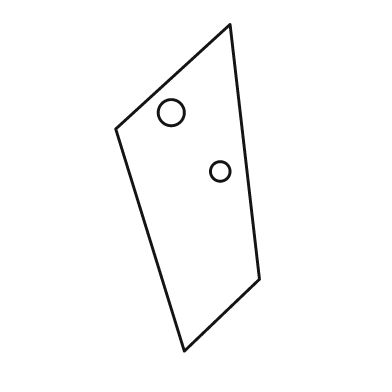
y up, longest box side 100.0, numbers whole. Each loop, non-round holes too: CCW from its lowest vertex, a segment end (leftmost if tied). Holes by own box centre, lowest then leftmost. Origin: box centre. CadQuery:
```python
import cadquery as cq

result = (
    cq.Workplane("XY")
    .moveTo(-1.0, -50.0)
    .lineTo(22.0, -28.0)
    .lineTo(13.0, 50.0)
    .lineTo(-22.0, 18.0)
    .close()
    .moveTo(10.0, 5.0)
    .circle(3.0)
    .moveTo(-5.0, 23.0)
    .circle(4.0)
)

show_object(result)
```